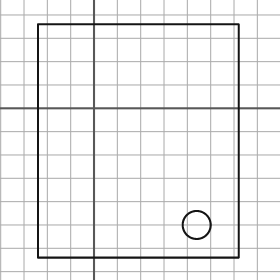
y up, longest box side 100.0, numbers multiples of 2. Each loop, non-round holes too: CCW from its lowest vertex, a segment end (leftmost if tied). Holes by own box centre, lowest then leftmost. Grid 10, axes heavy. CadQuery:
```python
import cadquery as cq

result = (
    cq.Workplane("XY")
    .moveTo(-24.0, -64.0)
    .lineTo(62.0, -64.0)
    .lineTo(62.0, 36.0)
    .lineTo(-24.0, 36.0)
    .close()
    .moveTo(44.0, -50.0)
    .circle(6.0)
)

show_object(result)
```